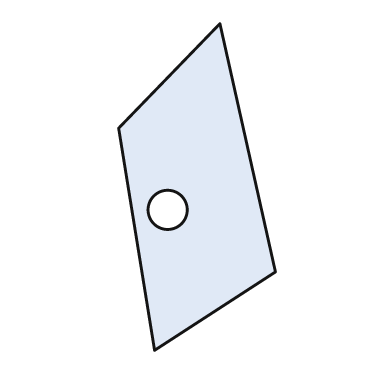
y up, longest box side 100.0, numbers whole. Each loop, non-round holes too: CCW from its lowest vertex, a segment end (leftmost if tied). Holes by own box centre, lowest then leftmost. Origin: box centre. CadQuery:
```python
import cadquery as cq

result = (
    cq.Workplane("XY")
    .moveTo(-13.0, -50.0)
    .lineTo(24.0, -26.0)
    .lineTo(7.0, 50.0)
    .lineTo(-24.0, 18.0)
    .close()
    .moveTo(-9.0, -7.0)
    .circle(6.0)
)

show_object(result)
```